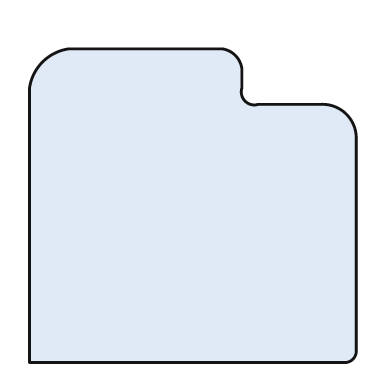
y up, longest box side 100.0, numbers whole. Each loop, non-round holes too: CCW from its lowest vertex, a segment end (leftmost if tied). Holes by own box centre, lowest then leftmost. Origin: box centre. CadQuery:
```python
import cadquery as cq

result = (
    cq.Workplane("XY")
    .moveTo(-50.0, -48.0)
    .lineTo(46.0, -48.0)
    .threePointArc((49.0, -47.0), (50.0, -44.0))
    .lineTo(50.0, 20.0)
    .threePointArc((47.0, 28.0), (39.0, 31.0))
    .lineTo(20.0, 31.0)
    .threePointArc((16.0, 32.0), (15.0, 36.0))
    .lineTo(15.0, 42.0)
    .threePointArc((13.0, 46.0), (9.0, 48.0))
    .lineTo(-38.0, 48.0)
    .threePointArc((-46.0, 44.0), (-50.0, 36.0))
    .close()
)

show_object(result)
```